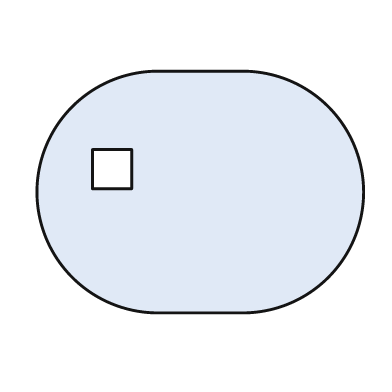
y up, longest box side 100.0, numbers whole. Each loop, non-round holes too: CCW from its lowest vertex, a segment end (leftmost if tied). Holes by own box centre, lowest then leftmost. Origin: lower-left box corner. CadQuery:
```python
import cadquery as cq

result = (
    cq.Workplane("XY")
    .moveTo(37.0, 0.0)
    .lineTo(63.0, 0.0)
    .threePointArc((100.0, 37.0), (63.0, 74.0))
    .lineTo(37.0, 74.0)
    .threePointArc((0.0, 37.0), (37.0, 0.0))
    .close()
    .moveTo(17.0, 38.0)
    .lineTo(29.0, 38.0)
    .lineTo(29.0, 50.0)
    .lineTo(17.0, 50.0)
    .close()
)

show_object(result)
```